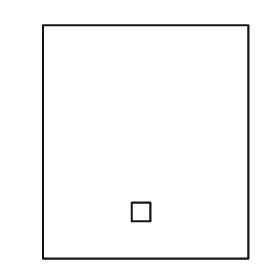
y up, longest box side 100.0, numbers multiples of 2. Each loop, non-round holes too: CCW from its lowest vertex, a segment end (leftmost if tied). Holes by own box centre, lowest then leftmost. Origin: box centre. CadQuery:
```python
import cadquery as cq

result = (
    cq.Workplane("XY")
    .moveTo(-44.0, -50.0)
    .lineTo(44.0, -50.0)
    .lineTo(44.0, 50.0)
    .lineTo(-44.0, 50.0)
    .close()
    .moveTo(-6.0, -34.0)
    .lineTo(2.0, -34.0)
    .lineTo(2.0, -26.0)
    .lineTo(-6.0, -26.0)
    .close()
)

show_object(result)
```